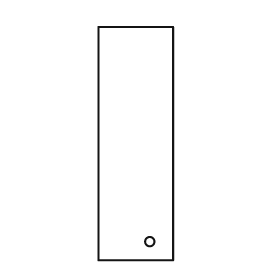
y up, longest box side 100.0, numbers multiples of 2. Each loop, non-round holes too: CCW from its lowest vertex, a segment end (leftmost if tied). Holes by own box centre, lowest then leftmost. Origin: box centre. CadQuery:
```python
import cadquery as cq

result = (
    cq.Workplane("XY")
    .moveTo(-16.0, -50.0)
    .lineTo(16.0, -50.0)
    .lineTo(16.0, 50.0)
    .lineTo(-16.0, 50.0)
    .close()
    .moveTo(6.0, -42.0)
    .circle(2.0)
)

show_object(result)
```